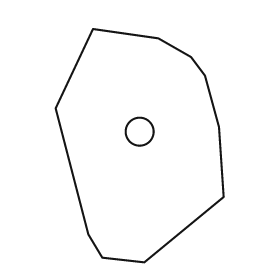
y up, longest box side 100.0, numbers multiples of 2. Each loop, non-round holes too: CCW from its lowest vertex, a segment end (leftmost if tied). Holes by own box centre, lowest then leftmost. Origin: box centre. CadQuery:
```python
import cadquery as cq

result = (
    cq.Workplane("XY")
    .moveTo(2.0, -50.0)
    .lineTo(36.0, -22.0)
    .lineTo(34.0, 8.0)
    .lineTo(28.0, 30.0)
    .lineTo(22.0, 38.0)
    .lineTo(8.0, 46.0)
    .lineTo(-20.0, 50.0)
    .lineTo(-36.0, 16.0)
    .lineTo(-22.0, -38.0)
    .lineTo(-16.0, -48.0)
    .close()
    .moveTo(0.0, 6.0)
    .circle(6.0)
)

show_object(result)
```